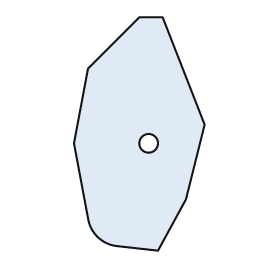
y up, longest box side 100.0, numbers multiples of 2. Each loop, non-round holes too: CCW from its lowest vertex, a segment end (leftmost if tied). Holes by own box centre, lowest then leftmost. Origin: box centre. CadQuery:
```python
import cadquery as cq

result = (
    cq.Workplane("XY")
    .moveTo(8.0, -50.0)
    .lineTo(20.0, -28.0)
    .lineTo(28.0, 4.0)
    .lineTo(10.0, 50.0)
    .lineTo(0.0, 50.0)
    .lineTo(-22.0, 28.0)
    .lineTo(-28.0, -4.0)
    .lineTo(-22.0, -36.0)
    .threePointArc((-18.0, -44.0), (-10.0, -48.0))
    .close()
    .moveTo(4.0, -4.0)
    .circle(4.0)
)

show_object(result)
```